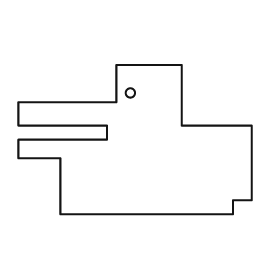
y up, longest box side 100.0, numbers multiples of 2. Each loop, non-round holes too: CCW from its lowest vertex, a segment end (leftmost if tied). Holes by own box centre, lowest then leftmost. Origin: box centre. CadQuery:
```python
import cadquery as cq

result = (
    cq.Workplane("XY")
    .moveTo(-32.0, -32.0)
    .lineTo(42.0, -32.0)
    .lineTo(42.0, -26.0)
    .lineTo(50.0, -26.0)
    .lineTo(50.0, 6.0)
    .lineTo(20.0, 6.0)
    .lineTo(20.0, 32.0)
    .lineTo(-8.0, 32.0)
    .lineTo(-8.0, 16.0)
    .lineTo(-50.0, 16.0)
    .lineTo(-50.0, 6.0)
    .lineTo(-12.0, 6.0)
    .lineTo(-12.0, 0.0)
    .lineTo(-50.0, 0.0)
    .lineTo(-50.0, -8.0)
    .lineTo(-32.0, -8.0)
    .close()
    .moveTo(-2.0, 20.0)
    .circle(2.0)
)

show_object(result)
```